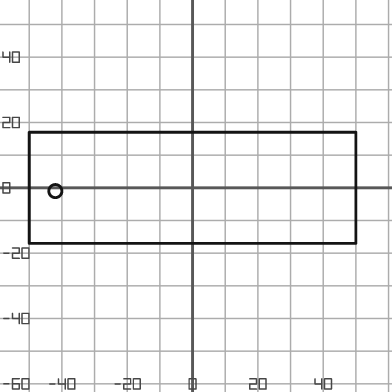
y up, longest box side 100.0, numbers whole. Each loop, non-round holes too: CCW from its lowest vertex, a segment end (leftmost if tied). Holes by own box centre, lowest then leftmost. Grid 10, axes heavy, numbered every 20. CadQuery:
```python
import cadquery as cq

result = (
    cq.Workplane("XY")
    .moveTo(-50.0, -17.0)
    .lineTo(50.0, -17.0)
    .lineTo(50.0, 17.0)
    .lineTo(-50.0, 17.0)
    .close()
    .moveTo(-42.0, -1.0)
    .circle(2.0)
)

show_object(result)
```